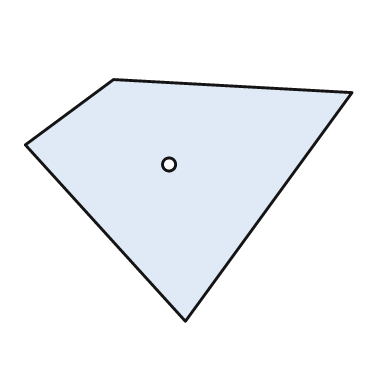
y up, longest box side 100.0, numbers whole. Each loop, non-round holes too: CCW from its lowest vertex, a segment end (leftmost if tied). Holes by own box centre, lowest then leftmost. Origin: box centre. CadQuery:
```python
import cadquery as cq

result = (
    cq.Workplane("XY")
    .moveTo(-1.0, -37.0)
    .lineTo(50.0, 33.0)
    .lineTo(-23.0, 37.0)
    .lineTo(-50.0, 17.0)
    .close()
    .moveTo(-6.0, 11.0)
    .circle(2.0)
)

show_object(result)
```